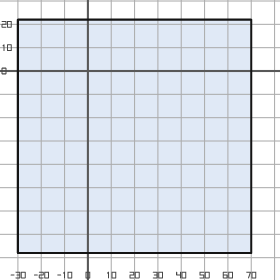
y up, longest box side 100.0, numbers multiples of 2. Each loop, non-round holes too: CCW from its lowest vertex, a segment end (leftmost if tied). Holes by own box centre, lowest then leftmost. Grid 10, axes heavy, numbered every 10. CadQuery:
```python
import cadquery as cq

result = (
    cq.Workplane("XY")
    .moveTo(-30.0, -78.0)
    .lineTo(70.0, -78.0)
    .lineTo(70.0, 22.0)
    .lineTo(-30.0, 22.0)
    .close()
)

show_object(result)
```